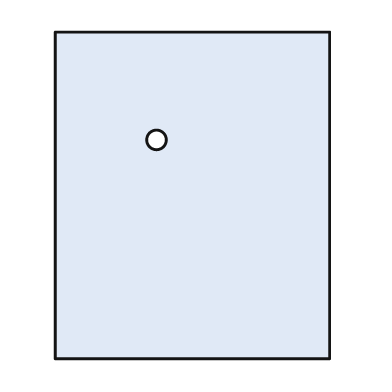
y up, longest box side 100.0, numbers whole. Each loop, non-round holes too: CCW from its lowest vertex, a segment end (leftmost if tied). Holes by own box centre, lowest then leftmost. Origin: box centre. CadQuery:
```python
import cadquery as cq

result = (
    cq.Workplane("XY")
    .moveTo(-42.0, -50.0)
    .lineTo(42.0, -50.0)
    .lineTo(42.0, 50.0)
    .lineTo(-42.0, 50.0)
    .close()
    .moveTo(-11.0, 17.0)
    .circle(3.0)
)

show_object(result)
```